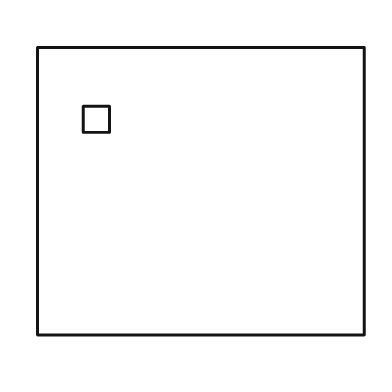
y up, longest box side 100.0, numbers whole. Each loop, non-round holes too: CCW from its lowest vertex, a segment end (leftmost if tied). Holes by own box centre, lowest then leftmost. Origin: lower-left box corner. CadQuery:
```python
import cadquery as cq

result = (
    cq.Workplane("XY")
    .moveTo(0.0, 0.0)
    .lineTo(100.0, 0.0)
    .lineTo(100.0, 88.0)
    .lineTo(0.0, 88.0)
    .close()
    .moveTo(14.0, 62.0)
    .lineTo(22.0, 62.0)
    .lineTo(22.0, 70.0)
    .lineTo(14.0, 70.0)
    .close()
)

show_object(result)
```